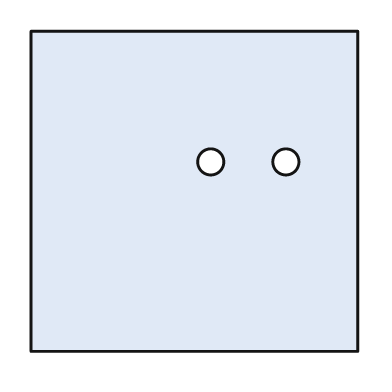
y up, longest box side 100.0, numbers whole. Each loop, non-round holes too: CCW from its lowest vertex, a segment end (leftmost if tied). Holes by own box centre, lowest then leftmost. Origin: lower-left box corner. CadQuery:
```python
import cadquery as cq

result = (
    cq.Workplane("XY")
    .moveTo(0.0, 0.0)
    .lineTo(100.0, 0.0)
    .lineTo(100.0, 98.0)
    .lineTo(0.0, 98.0)
    .close()
    .moveTo(55.0, 58.0)
    .circle(4.0)
    .moveTo(78.0, 58.0)
    .circle(4.0)
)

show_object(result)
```